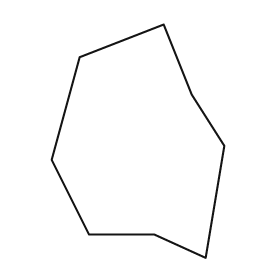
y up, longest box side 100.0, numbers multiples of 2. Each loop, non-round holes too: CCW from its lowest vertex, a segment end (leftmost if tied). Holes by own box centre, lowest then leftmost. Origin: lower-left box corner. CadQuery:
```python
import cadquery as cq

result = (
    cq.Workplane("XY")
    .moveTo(66.0, 0.0)
    .lineTo(74.0, 48.0)
    .lineTo(60.0, 70.0)
    .lineTo(48.0, 100.0)
    .lineTo(12.0, 86.0)
    .lineTo(0.0, 42.0)
    .lineTo(16.0, 10.0)
    .lineTo(44.0, 10.0)
    .close()
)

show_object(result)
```